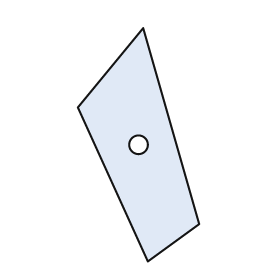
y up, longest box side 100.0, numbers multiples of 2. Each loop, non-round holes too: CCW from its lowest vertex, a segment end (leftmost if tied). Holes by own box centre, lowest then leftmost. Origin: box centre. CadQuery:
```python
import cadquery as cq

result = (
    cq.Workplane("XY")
    .moveTo(4.0, -50.0)
    .lineTo(26.0, -34.0)
    .lineTo(2.0, 50.0)
    .lineTo(-26.0, 16.0)
    .close()
    .moveTo(0.0, 0.0)
    .circle(4.0)
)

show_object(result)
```